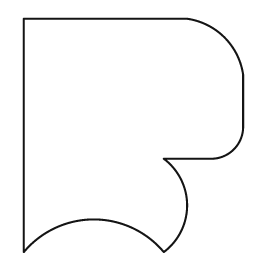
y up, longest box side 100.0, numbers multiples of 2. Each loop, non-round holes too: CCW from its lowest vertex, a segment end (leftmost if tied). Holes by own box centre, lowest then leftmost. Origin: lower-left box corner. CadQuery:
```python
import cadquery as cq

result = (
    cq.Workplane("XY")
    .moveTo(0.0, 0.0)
    .threePointArc((30.0, 14.0), (60.0, 0.0))
    .threePointArc((70.0, 20.0), (60.0, 40.0))
    .lineTo(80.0, 40.0)
    .threePointArc((90.0, 44.0), (94.0, 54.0))
    .lineTo(94.0, 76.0)
    .threePointArc((86.0, 92.0), (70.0, 100.0))
    .lineTo(0.0, 100.0)
    .close()
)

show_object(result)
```